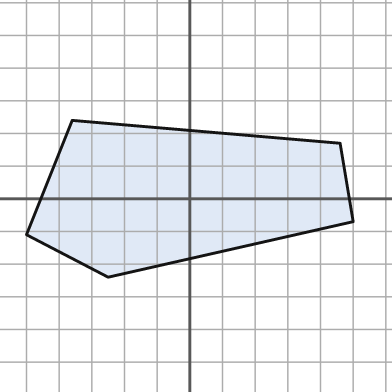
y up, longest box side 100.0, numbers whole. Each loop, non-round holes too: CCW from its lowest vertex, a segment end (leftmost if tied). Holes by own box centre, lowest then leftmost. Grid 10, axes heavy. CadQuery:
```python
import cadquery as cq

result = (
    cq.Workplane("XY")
    .moveTo(-25.0, -24.0)
    .lineTo(50.0, -7.0)
    .lineTo(46.0, 17.0)
    .lineTo(-36.0, 24.0)
    .lineTo(-50.0, -11.0)
    .close()
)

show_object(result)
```